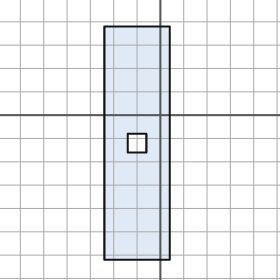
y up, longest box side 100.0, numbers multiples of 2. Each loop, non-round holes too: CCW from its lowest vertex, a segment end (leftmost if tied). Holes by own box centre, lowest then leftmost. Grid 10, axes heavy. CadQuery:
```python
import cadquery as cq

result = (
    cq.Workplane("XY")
    .moveTo(-24.0, -62.0)
    .lineTo(4.0, -62.0)
    .lineTo(4.0, 38.0)
    .lineTo(-24.0, 38.0)
    .close()
    .moveTo(-14.0, -16.0)
    .lineTo(-6.0, -16.0)
    .lineTo(-6.0, -8.0)
    .lineTo(-14.0, -8.0)
    .close()
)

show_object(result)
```